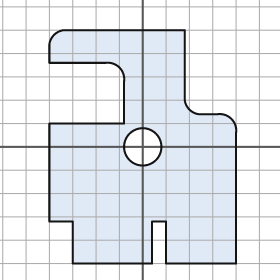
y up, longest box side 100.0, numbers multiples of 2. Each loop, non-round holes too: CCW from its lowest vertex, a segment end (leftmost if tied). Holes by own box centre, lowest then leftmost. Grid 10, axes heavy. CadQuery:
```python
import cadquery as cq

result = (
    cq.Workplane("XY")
    .moveTo(-30.0, -50.0)
    .lineTo(4.0, -50.0)
    .lineTo(4.0, -32.0)
    .lineTo(10.0, -32.0)
    .lineTo(10.0, -50.0)
    .lineTo(40.0, -50.0)
    .lineTo(40.0, 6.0)
    .threePointArc((38.0, 12.0), (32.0, 14.0))
    .lineTo(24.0, 14.0)
    .threePointArc((20.0, 16.0), (18.0, 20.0))
    .lineTo(18.0, 50.0)
    .lineTo(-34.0, 50.0)
    .threePointArc((-38.0, 48.0), (-40.0, 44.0))
    .lineTo(-40.0, 36.0)
    .lineTo(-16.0, 36.0)
    .threePointArc((-10.0, 34.0), (-8.0, 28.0))
    .lineTo(-8.0, 10.0)
    .lineTo(-40.0, 10.0)
    .lineTo(-40.0, -32.0)
    .lineTo(-30.0, -32.0)
    .close()
    .moveTo(0.0, 0.0)
    .circle(8.0)
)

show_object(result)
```